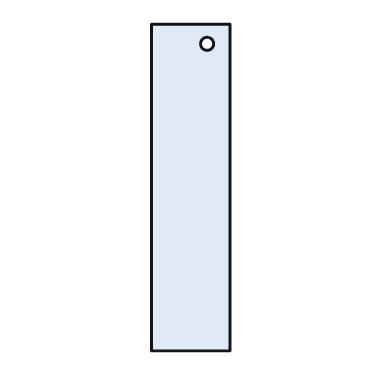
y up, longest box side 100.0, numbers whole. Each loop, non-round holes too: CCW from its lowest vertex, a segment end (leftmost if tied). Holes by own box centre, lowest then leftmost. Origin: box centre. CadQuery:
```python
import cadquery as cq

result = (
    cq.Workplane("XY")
    .moveTo(-12.0, -50.0)
    .lineTo(12.0, -50.0)
    .lineTo(12.0, 50.0)
    .lineTo(-12.0, 50.0)
    .close()
    .moveTo(5.0, 44.0)
    .circle(2.0)
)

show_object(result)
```